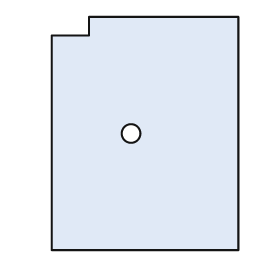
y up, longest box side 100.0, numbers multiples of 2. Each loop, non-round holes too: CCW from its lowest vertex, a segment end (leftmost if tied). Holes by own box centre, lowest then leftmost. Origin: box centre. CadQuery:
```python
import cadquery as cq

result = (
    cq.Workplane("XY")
    .moveTo(-40.0, -50.0)
    .lineTo(40.0, -50.0)
    .lineTo(40.0, 50.0)
    .lineTo(-24.0, 50.0)
    .lineTo(-24.0, 42.0)
    .lineTo(-40.0, 42.0)
    .close()
    .moveTo(-6.0, 0.0)
    .circle(4.0)
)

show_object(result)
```